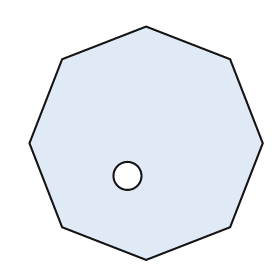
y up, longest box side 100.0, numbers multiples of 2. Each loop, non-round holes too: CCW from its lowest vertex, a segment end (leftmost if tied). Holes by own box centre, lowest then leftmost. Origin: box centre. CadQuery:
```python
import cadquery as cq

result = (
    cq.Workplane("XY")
    .moveTo(0.0, -50.0)
    .lineTo(36.0, -36.0)
    .lineTo(50.0, 0.0)
    .lineTo(36.0, 36.0)
    .lineTo(0.0, 50.0)
    .lineTo(-36.0, 36.0)
    .lineTo(-50.0, 0.0)
    .lineTo(-36.0, -36.0)
    .close()
    .moveTo(-8.0, -14.0)
    .circle(6.0)
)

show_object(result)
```